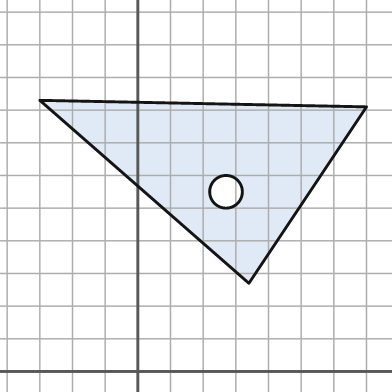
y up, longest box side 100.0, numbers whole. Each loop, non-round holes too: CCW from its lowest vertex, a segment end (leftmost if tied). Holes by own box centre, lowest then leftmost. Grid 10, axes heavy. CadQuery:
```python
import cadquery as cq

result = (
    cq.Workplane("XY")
    .moveTo(34.0, 27.0)
    .lineTo(70.0, 81.0)
    .lineTo(-30.0, 83.0)
    .close()
    .moveTo(27.0, 55.0)
    .circle(5.0)
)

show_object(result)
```